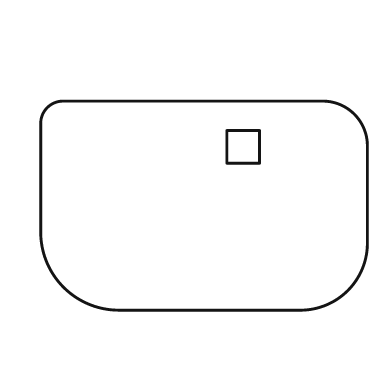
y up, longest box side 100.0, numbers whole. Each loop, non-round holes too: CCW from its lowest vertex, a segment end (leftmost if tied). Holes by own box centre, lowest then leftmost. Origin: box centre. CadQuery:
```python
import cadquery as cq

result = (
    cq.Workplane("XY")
    .moveTo(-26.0, -32.0)
    .lineTo(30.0, -32.0)
    .threePointArc((44.0, -26.0), (50.0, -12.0))
    .lineTo(50.0, 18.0)
    .threePointArc((46.0, 28.0), (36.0, 32.0))
    .lineTo(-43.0, 32.0)
    .threePointArc((-48.0, 30.0), (-50.0, 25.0))
    .lineTo(-50.0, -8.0)
    .threePointArc((-43.0, -25.0), (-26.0, -32.0))
    .close()
    .moveTo(7.0, 13.0)
    .lineTo(17.0, 13.0)
    .lineTo(17.0, 23.0)
    .lineTo(7.0, 23.0)
    .close()
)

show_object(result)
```